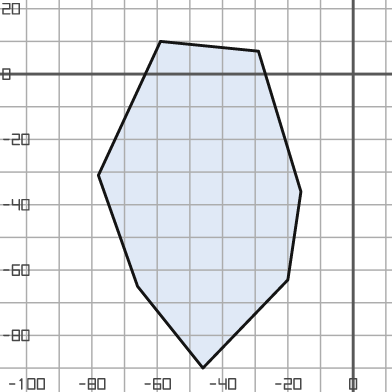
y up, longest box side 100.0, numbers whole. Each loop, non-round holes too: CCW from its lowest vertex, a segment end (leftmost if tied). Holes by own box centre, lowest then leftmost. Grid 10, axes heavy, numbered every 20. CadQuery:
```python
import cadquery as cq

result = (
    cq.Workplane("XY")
    .moveTo(-46.0, -90.0)
    .lineTo(-20.0, -63.0)
    .lineTo(-16.0, -36.0)
    .lineTo(-29.0, 7.0)
    .lineTo(-59.0, 10.0)
    .lineTo(-78.0, -31.0)
    .lineTo(-66.0, -65.0)
    .close()
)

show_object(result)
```